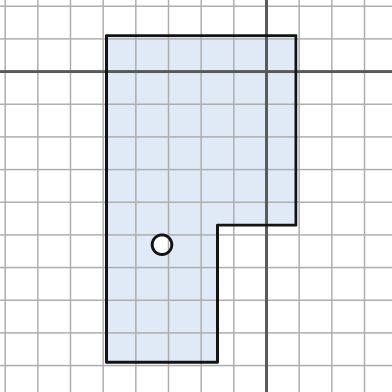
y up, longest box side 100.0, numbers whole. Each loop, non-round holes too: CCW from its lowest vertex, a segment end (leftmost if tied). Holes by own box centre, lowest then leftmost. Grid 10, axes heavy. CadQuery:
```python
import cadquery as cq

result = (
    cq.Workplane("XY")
    .moveTo(-49.0, -89.0)
    .lineTo(-15.0, -89.0)
    .lineTo(-15.0, -47.0)
    .lineTo(9.0, -47.0)
    .lineTo(9.0, 11.0)
    .lineTo(-49.0, 11.0)
    .close()
    .moveTo(-32.0, -53.0)
    .circle(3.0)
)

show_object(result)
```